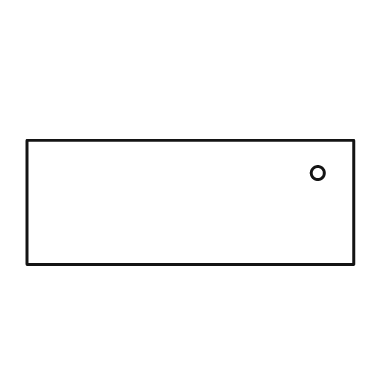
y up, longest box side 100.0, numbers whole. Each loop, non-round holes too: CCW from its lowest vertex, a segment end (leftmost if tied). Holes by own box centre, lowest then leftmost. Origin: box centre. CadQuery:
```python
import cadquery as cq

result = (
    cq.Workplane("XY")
    .moveTo(-50.0, -19.0)
    .lineTo(50.0, -19.0)
    .lineTo(50.0, 19.0)
    .lineTo(-50.0, 19.0)
    .close()
    .moveTo(39.0, 9.0)
    .circle(2.0)
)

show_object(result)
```